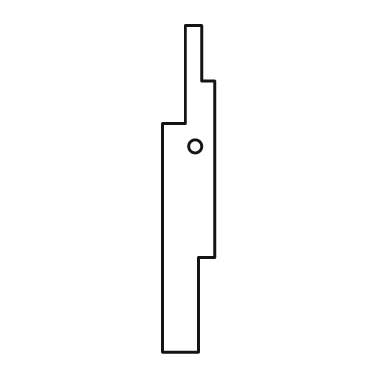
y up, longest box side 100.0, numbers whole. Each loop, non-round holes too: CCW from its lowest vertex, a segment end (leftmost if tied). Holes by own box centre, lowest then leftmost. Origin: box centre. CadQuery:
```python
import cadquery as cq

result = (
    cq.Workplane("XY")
    .moveTo(-8.0, -50.0)
    .lineTo(3.0, -50.0)
    .lineTo(3.0, -21.0)
    .lineTo(8.0, -21.0)
    .lineTo(8.0, 33.0)
    .lineTo(4.0, 33.0)
    .lineTo(4.0, 50.0)
    .lineTo(-1.0, 50.0)
    .lineTo(-1.0, 20.0)
    .lineTo(-8.0, 20.0)
    .close()
    .moveTo(2.0, 13.0)
    .circle(2.0)
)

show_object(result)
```